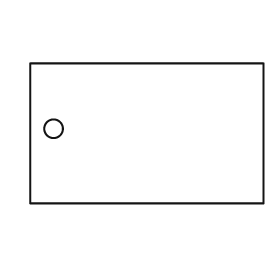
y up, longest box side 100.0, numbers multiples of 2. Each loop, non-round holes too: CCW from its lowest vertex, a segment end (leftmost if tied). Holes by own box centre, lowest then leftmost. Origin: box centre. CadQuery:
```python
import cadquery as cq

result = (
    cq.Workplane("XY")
    .moveTo(-50.0, -30.0)
    .lineTo(50.0, -30.0)
    .lineTo(50.0, 30.0)
    .lineTo(-50.0, 30.0)
    .close()
    .moveTo(-40.0, 2.0)
    .circle(4.0)
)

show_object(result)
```